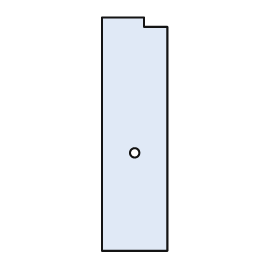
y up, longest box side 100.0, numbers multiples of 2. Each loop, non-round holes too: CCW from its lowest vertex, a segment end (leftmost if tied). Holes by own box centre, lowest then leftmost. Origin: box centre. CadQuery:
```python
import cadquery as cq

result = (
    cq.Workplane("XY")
    .moveTo(-14.0, -50.0)
    .lineTo(14.0, -50.0)
    .lineTo(14.0, 46.0)
    .lineTo(4.0, 46.0)
    .lineTo(4.0, 50.0)
    .lineTo(-14.0, 50.0)
    .close()
    .moveTo(0.0, -8.0)
    .circle(2.0)
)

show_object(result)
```